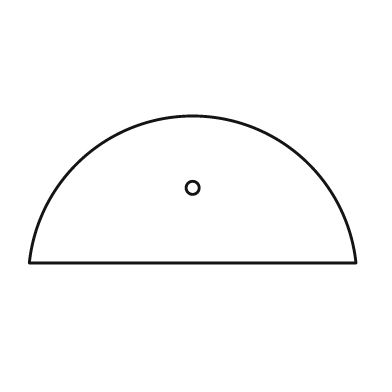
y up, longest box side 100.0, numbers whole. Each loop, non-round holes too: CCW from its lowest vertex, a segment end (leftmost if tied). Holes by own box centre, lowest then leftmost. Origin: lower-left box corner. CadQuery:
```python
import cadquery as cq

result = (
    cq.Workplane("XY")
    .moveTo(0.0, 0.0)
    .lineTo(100.0, 0.0)
    .threePointArc((50.0, 45.0), (0.0, 0.0))
    .close()
    .moveTo(50.0, 23.0)
    .circle(2.0)
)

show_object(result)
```